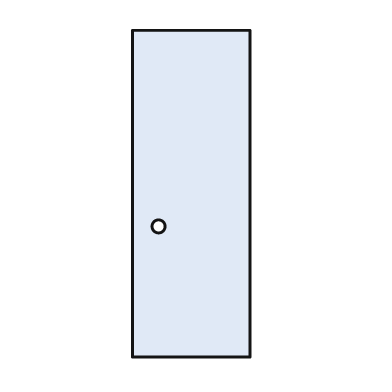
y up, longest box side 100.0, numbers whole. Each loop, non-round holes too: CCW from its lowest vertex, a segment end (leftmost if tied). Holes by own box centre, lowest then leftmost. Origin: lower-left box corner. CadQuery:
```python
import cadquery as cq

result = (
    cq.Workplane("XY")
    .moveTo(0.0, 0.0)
    .lineTo(36.0, 0.0)
    .lineTo(36.0, 100.0)
    .lineTo(0.0, 100.0)
    .close()
    .moveTo(8.0, 40.0)
    .circle(2.0)
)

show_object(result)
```